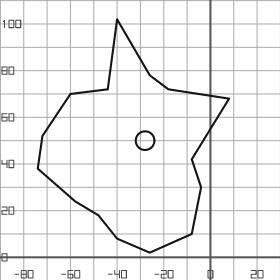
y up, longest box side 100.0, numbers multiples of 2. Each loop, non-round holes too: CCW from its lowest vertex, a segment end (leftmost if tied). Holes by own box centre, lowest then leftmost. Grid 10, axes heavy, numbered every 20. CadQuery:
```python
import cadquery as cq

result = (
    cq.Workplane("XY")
    .moveTo(-26.0, 2.0)
    .lineTo(-8.0, 10.0)
    .lineTo(-4.0, 30.0)
    .lineTo(-8.0, 42.0)
    .lineTo(8.0, 68.0)
    .lineTo(-18.0, 72.0)
    .lineTo(-26.0, 78.0)
    .lineTo(-40.0, 102.0)
    .lineTo(-44.0, 72.0)
    .lineTo(-60.0, 70.0)
    .lineTo(-72.0, 52.0)
    .lineTo(-74.0, 38.0)
    .lineTo(-58.0, 24.0)
    .lineTo(-48.0, 18.0)
    .lineTo(-40.0, 8.0)
    .close()
    .moveTo(-28.0, 50.0)
    .circle(4.0)
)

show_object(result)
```